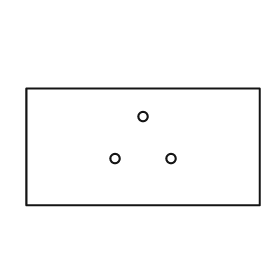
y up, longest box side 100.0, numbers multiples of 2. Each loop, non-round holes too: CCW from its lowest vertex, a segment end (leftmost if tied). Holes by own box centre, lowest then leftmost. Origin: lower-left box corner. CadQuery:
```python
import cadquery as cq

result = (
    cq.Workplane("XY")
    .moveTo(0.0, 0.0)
    .lineTo(100.0, 0.0)
    .lineTo(100.0, 50.0)
    .lineTo(0.0, 50.0)
    .close()
    .moveTo(38.0, 20.0)
    .circle(2.0)
    .moveTo(62.0, 20.0)
    .circle(2.0)
    .moveTo(50.0, 38.0)
    .circle(2.0)
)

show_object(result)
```